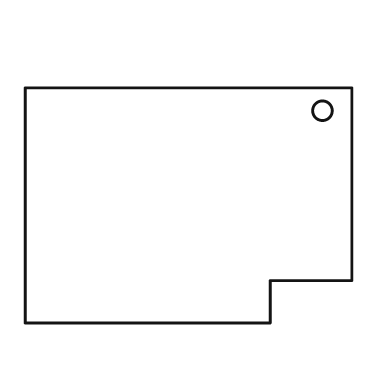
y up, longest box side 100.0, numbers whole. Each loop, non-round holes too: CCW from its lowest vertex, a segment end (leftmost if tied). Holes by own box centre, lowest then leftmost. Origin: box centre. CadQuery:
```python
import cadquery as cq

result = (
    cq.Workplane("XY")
    .moveTo(-50.0, -36.0)
    .lineTo(25.0, -36.0)
    .lineTo(25.0, -23.0)
    .lineTo(50.0, -23.0)
    .lineTo(50.0, 36.0)
    .lineTo(-50.0, 36.0)
    .close()
    .moveTo(41.0, 29.0)
    .circle(3.0)
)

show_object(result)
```